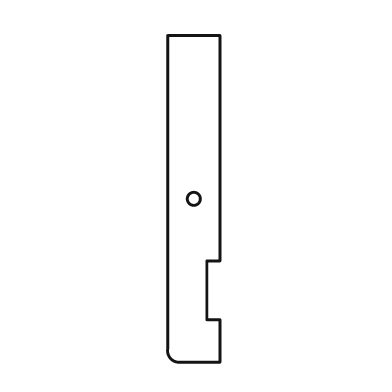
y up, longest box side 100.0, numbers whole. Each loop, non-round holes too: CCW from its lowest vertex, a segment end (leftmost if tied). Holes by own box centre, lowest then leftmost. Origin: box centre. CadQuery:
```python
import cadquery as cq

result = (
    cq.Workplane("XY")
    .moveTo(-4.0, -50.0)
    .lineTo(8.0, -50.0)
    .lineTo(8.0, -37.0)
    .lineTo(4.0, -37.0)
    .lineTo(4.0, -19.0)
    .lineTo(8.0, -19.0)
    .lineTo(8.0, 50.0)
    .lineTo(-8.0, 50.0)
    .lineTo(-8.0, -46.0)
    .threePointArc((-7.0, -49.0), (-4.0, -50.0))
    .close()
    .moveTo(0.0, 0.0)
    .circle(2.0)
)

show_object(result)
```